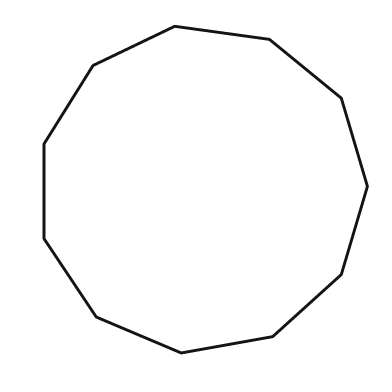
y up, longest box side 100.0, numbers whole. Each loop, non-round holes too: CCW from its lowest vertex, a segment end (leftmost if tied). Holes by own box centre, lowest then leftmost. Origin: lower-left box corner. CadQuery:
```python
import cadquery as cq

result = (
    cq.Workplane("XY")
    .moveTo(42.0, 0.0)
    .lineTo(70.0, 5.0)
    .lineTo(91.0, 24.0)
    .lineTo(99.0, 51.0)
    .lineTo(91.0, 78.0)
    .lineTo(69.0, 96.0)
    .lineTo(40.0, 100.0)
    .lineTo(15.0, 88.0)
    .lineTo(0.0, 64.0)
    .lineTo(0.0, 35.0)
    .lineTo(16.0, 11.0)
    .close()
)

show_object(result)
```